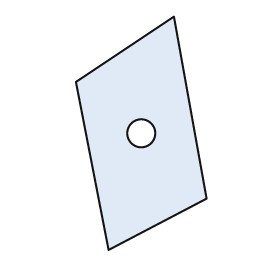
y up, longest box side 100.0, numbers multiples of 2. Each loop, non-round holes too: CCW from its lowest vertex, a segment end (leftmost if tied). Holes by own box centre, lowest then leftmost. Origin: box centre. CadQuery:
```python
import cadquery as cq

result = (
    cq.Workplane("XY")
    .moveTo(-14.0, -50.0)
    .lineTo(28.0, -28.0)
    .lineTo(14.0, 50.0)
    .lineTo(-28.0, 22.0)
    .close()
    .moveTo(0.0, 0.0)
    .circle(6.0)
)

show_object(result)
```